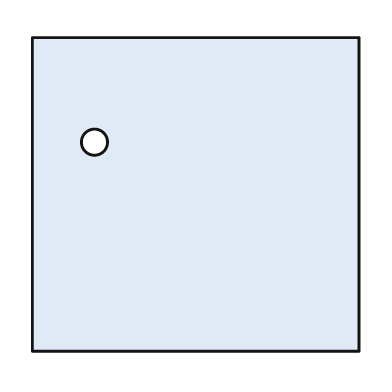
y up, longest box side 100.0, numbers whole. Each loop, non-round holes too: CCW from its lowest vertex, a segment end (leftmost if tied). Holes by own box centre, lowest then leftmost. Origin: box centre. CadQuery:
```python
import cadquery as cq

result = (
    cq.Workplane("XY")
    .moveTo(-50.0, -48.0)
    .lineTo(50.0, -48.0)
    .lineTo(50.0, 48.0)
    .lineTo(-50.0, 48.0)
    .close()
    .moveTo(-31.0, 16.0)
    .circle(4.0)
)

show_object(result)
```